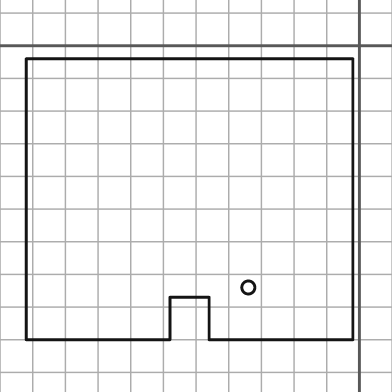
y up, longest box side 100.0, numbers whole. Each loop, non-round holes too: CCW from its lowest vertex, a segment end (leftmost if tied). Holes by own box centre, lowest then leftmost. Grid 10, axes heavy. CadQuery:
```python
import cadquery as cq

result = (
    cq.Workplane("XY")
    .moveTo(-102.0, -90.0)
    .lineTo(-58.0, -90.0)
    .lineTo(-58.0, -77.0)
    .lineTo(-46.0, -77.0)
    .lineTo(-46.0, -90.0)
    .lineTo(-2.0, -90.0)
    .lineTo(-2.0, -4.0)
    .lineTo(-102.0, -4.0)
    .close()
    .moveTo(-34.0, -74.0)
    .circle(2.0)
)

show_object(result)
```